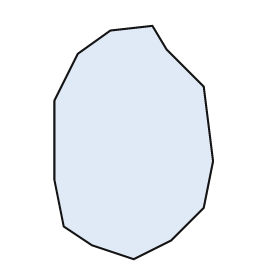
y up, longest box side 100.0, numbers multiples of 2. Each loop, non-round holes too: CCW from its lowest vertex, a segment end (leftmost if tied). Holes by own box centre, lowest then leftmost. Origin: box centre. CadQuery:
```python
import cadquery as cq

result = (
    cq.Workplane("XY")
    .moveTo(0.0, -50.0)
    .lineTo(16.0, -42.0)
    .lineTo(30.0, -28.0)
    .lineTo(34.0, -8.0)
    .lineTo(30.0, 24.0)
    .lineTo(14.0, 40.0)
    .lineTo(8.0, 50.0)
    .lineTo(-10.0, 48.0)
    .lineTo(-24.0, 38.0)
    .lineTo(-34.0, 18.0)
    .lineTo(-34.0, -16.0)
    .lineTo(-30.0, -36.0)
    .lineTo(-18.0, -44.0)
    .close()
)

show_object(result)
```